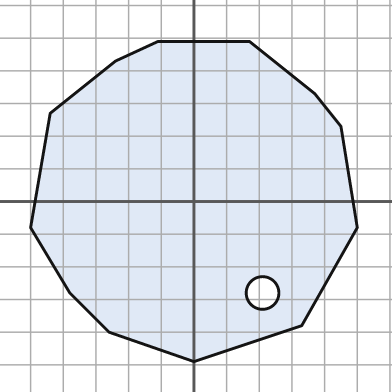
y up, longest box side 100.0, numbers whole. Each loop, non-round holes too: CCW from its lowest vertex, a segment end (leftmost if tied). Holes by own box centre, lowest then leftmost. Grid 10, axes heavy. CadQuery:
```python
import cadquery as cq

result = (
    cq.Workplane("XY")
    .moveTo(0.0, -49.0)
    .lineTo(33.0, -38.0)
    .lineTo(50.0, -8.0)
    .lineTo(45.0, 23.0)
    .lineTo(37.0, 33.0)
    .lineTo(17.0, 49.0)
    .lineTo(-11.0, 49.0)
    .lineTo(-24.0, 43.0)
    .lineTo(-44.0, 27.0)
    .lineTo(-50.0, -8.0)
    .lineTo(-38.0, -28.0)
    .lineTo(-26.0, -40.0)
    .close()
    .moveTo(21.0, -28.0)
    .circle(5.0)
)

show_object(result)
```